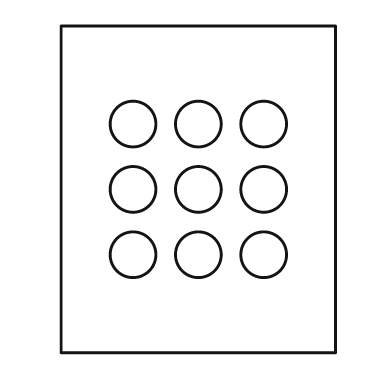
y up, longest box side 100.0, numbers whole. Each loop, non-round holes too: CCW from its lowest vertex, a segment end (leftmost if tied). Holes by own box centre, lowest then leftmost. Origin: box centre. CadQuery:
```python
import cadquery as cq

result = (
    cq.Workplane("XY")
    .moveTo(-42.0, -50.0)
    .lineTo(42.0, -50.0)
    .lineTo(42.0, 50.0)
    .lineTo(-42.0, 50.0)
    .close()
    .moveTo(-20.0, -20.0)
    .circle(7.0)
    .moveTo(0.0, -20.0)
    .circle(7.0)
    .moveTo(20.0, -20.0)
    .circle(7.0)
    .moveTo(-20.0, 0.0)
    .circle(7.0)
    .moveTo(0.0, 0.0)
    .circle(7.0)
    .moveTo(20.0, 0.0)
    .circle(7.0)
    .moveTo(-20.0, 20.0)
    .circle(7.0)
    .moveTo(0.0, 20.0)
    .circle(7.0)
    .moveTo(20.0, 20.0)
    .circle(7.0)
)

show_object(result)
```